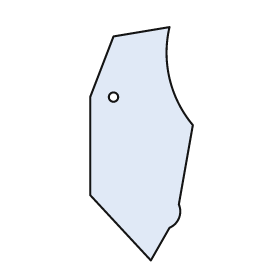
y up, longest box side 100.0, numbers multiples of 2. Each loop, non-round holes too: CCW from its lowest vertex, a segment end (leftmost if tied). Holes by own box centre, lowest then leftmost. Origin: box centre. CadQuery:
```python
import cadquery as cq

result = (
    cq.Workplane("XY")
    .moveTo(4.0, -50.0)
    .lineTo(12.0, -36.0)
    .threePointArc((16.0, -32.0), (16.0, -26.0))
    .lineTo(22.0, 8.0)
    .threePointArc((12.0, 28.0), (12.0, 50.0))
    .lineTo(-12.0, 46.0)
    .lineTo(-22.0, 20.0)
    .lineTo(-22.0, -22.0)
    .close()
    .moveTo(-12.0, 20.0)
    .circle(2.0)
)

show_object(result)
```